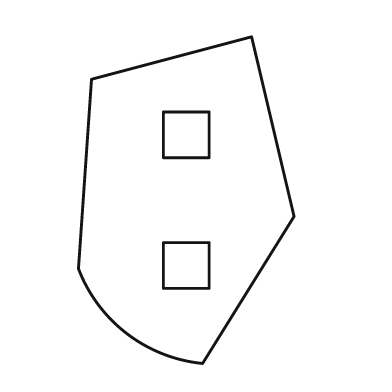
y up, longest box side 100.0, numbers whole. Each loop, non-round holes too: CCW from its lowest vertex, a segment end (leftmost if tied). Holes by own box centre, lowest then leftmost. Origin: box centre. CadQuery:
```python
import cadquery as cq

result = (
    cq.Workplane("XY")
    .moveTo(5.0, -50.0)
    .lineTo(33.0, -5.0)
    .lineTo(20.0, 50.0)
    .lineTo(-29.0, 37.0)
    .lineTo(-33.0, -21.0)
    .threePointArc((-18.0, -41.0), (5.0, -50.0))
    .close()
    .moveTo(-7.0, -27.0)
    .lineTo(7.0, -27.0)
    .lineTo(7.0, -13.0)
    .lineTo(-7.0, -13.0)
    .close()
    .moveTo(-7.0, 13.0)
    .lineTo(7.0, 13.0)
    .lineTo(7.0, 27.0)
    .lineTo(-7.0, 27.0)
    .close()
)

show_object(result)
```